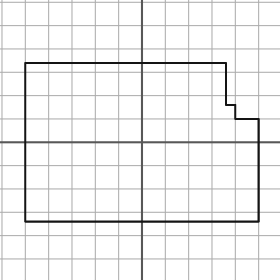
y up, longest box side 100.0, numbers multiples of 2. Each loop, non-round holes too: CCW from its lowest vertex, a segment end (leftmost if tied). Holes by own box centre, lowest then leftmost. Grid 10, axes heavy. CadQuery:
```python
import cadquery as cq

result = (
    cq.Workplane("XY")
    .moveTo(-50.0, -34.0)
    .lineTo(50.0, -34.0)
    .lineTo(50.0, 10.0)
    .lineTo(40.0, 10.0)
    .lineTo(40.0, 16.0)
    .lineTo(36.0, 16.0)
    .lineTo(36.0, 34.0)
    .lineTo(-50.0, 34.0)
    .close()
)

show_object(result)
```